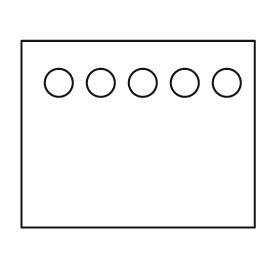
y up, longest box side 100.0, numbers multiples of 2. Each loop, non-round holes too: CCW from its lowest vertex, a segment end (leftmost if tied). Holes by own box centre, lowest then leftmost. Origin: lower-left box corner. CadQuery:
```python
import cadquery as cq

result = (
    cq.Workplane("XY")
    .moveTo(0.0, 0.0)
    .lineTo(100.0, 0.0)
    .lineTo(100.0, 80.0)
    .lineTo(0.0, 80.0)
    .close()
    .moveTo(16.0, 62.0)
    .circle(6.0)
    .moveTo(34.0, 62.0)
    .circle(6.0)
    .moveTo(52.0, 62.0)
    .circle(6.0)
    .moveTo(70.0, 62.0)
    .circle(6.0)
    .moveTo(88.0, 62.0)
    .circle(6.0)
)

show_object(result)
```